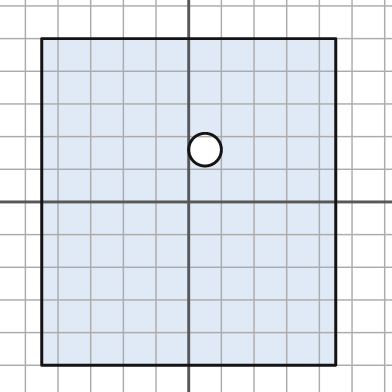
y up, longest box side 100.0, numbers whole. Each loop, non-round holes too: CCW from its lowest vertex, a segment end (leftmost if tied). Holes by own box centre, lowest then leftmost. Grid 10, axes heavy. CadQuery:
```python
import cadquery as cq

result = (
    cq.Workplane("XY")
    .moveTo(-45.0, -50.0)
    .lineTo(45.0, -50.0)
    .lineTo(45.0, 50.0)
    .lineTo(-45.0, 50.0)
    .close()
    .moveTo(5.0, 16.0)
    .circle(5.0)
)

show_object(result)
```